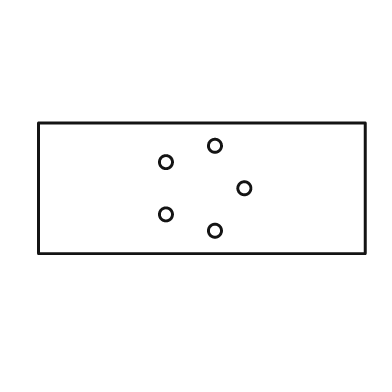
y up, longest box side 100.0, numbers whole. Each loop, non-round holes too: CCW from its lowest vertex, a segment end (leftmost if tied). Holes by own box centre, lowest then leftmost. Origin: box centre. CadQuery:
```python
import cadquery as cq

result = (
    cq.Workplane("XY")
    .moveTo(-50.0, -20.0)
    .lineTo(50.0, -20.0)
    .lineTo(50.0, 20.0)
    .lineTo(-50.0, 20.0)
    .close()
    .moveTo(4.0, -13.0)
    .circle(2.0)
    .moveTo(-11.0, -8.0)
    .circle(2.0)
    .moveTo(13.0, 0.0)
    .circle(2.0)
    .moveTo(-11.0, 8.0)
    .circle(2.0)
    .moveTo(4.0, 13.0)
    .circle(2.0)
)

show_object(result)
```